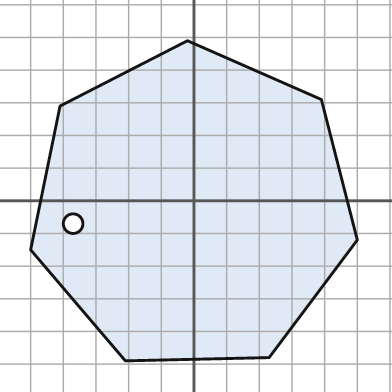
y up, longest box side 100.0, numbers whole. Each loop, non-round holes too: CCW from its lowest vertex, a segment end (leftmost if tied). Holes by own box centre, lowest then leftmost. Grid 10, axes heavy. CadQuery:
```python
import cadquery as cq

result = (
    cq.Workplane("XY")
    .moveTo(-21.0, -49.0)
    .lineTo(23.0, -48.0)
    .lineTo(50.0, -12.0)
    .lineTo(39.0, 31.0)
    .lineTo(-2.0, 49.0)
    .lineTo(-41.0, 29.0)
    .lineTo(-50.0, -15.0)
    .close()
    .moveTo(-37.0, -7.0)
    .circle(3.0)
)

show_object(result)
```